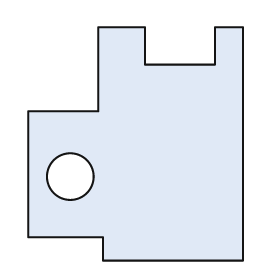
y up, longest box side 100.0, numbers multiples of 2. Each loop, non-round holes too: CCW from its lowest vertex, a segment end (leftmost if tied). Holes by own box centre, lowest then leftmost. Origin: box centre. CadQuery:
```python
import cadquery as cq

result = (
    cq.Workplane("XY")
    .moveTo(-14.0, -50.0)
    .lineTo(46.0, -50.0)
    .lineTo(46.0, 50.0)
    .lineTo(34.0, 50.0)
    .lineTo(34.0, 34.0)
    .lineTo(4.0, 34.0)
    .lineTo(4.0, 50.0)
    .lineTo(-16.0, 50.0)
    .lineTo(-16.0, 14.0)
    .lineTo(-46.0, 14.0)
    .lineTo(-46.0, -40.0)
    .lineTo(-14.0, -40.0)
    .close()
    .moveTo(-28.0, -14.0)
    .circle(10.0)
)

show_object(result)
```